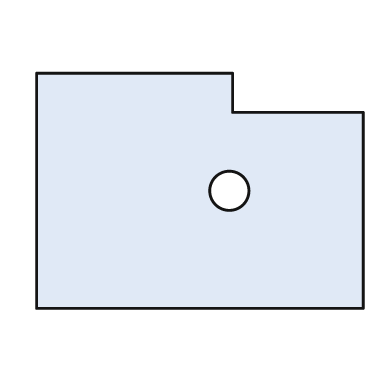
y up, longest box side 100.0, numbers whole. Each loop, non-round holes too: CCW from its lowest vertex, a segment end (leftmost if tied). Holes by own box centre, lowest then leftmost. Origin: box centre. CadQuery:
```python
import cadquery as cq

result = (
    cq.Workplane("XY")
    .moveTo(-50.0, -36.0)
    .lineTo(50.0, -36.0)
    .lineTo(50.0, 24.0)
    .lineTo(10.0, 24.0)
    .lineTo(10.0, 36.0)
    .lineTo(-50.0, 36.0)
    .close()
    .moveTo(9.0, 0.0)
    .circle(6.0)
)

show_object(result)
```